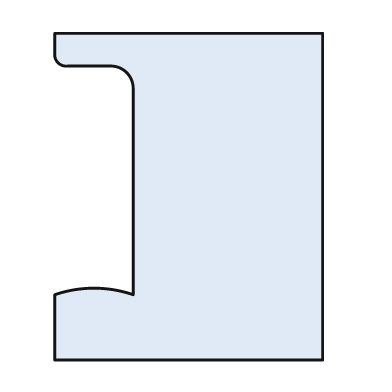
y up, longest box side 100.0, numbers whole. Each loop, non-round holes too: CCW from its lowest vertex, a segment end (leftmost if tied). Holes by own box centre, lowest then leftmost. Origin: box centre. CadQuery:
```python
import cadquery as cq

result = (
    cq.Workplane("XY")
    .moveTo(-41.0, -50.0)
    .lineTo(41.0, -50.0)
    .lineTo(41.0, 50.0)
    .lineTo(-41.0, 50.0)
    .lineTo(-41.0, 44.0)
    .threePointArc((-40.0, 41.0), (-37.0, 40.0))
    .lineTo(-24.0, 40.0)
    .threePointArc((-19.0, 38.0), (-17.0, 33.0))
    .lineTo(-17.0, -30.0)
    .threePointArc((-29.0, -28.0), (-41.0, -30.0))
    .close()
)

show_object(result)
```